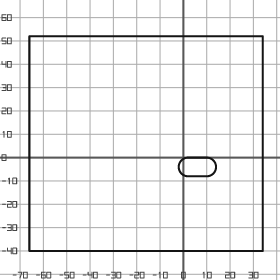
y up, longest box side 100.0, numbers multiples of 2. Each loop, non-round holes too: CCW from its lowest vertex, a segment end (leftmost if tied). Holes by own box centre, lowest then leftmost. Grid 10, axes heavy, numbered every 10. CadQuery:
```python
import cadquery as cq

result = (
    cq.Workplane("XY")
    .moveTo(-66.0, -40.0)
    .lineTo(34.0, -40.0)
    .lineTo(34.0, 52.0)
    .lineTo(-66.0, 52.0)
    .close()
    .moveTo(2.0, -8.0)
    .lineTo(10.0, -8.0)
    .threePointArc((14.0, -4.0), (10.0, 0.0))
    .lineTo(2.0, 0.0)
    .threePointArc((-2.0, -4.0), (2.0, -8.0))
    .close()
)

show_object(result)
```